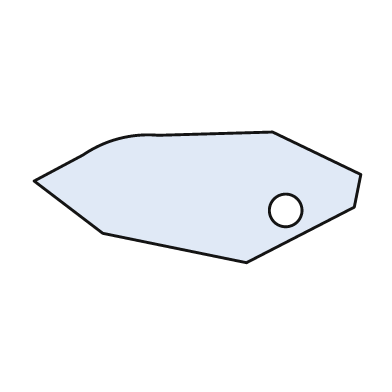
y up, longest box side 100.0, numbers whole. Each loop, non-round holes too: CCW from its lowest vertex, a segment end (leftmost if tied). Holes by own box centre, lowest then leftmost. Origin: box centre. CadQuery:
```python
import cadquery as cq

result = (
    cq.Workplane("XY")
    .moveTo(15.0, -20.0)
    .lineTo(48.0, -3.0)
    .lineTo(50.0, 7.0)
    .lineTo(23.0, 20.0)
    .lineTo(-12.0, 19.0)
    .threePointArc((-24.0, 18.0), (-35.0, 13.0))
    .lineTo(-50.0, 5.0)
    .lineTo(-29.0, -11.0)
    .close()
    .moveTo(27.0, -4.0)
    .circle(5.0)
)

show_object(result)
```